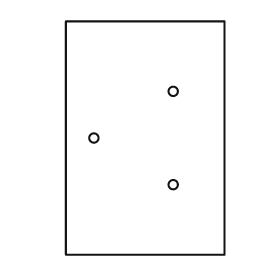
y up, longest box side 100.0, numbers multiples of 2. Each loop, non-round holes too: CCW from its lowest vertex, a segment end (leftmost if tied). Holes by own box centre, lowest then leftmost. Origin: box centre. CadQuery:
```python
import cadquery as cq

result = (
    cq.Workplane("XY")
    .moveTo(-34.0, -50.0)
    .lineTo(34.0, -50.0)
    .lineTo(34.0, 50.0)
    .lineTo(-34.0, 50.0)
    .close()
    .moveTo(12.0, -20.0)
    .circle(2.0)
    .moveTo(-22.0, 0.0)
    .circle(2.0)
    .moveTo(12.0, 20.0)
    .circle(2.0)
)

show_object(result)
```